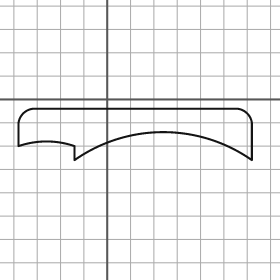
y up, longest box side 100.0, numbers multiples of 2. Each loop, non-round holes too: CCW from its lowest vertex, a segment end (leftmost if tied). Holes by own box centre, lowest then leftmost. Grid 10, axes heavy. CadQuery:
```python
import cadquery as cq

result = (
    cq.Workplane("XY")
    .moveTo(-14.0, -26.0)
    .threePointArc((24.0, -14.0), (62.0, -26.0))
    .lineTo(62.0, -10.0)
    .threePointArc((60.0, -6.0), (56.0, -4.0))
    .lineTo(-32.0, -4.0)
    .threePointArc((-36.0, -6.0), (-38.0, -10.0))
    .lineTo(-38.0, -20.0)
    .threePointArc((-26.0, -18.0), (-14.0, -20.0))
    .close()
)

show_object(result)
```